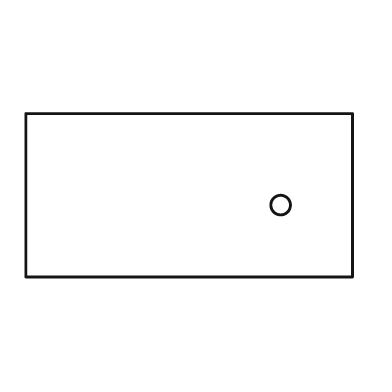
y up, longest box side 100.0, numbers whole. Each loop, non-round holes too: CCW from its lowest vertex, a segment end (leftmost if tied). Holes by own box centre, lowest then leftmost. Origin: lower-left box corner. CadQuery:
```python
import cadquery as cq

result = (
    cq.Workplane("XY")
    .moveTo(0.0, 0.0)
    .lineTo(100.0, 0.0)
    .lineTo(100.0, 50.0)
    .lineTo(0.0, 50.0)
    .close()
    .moveTo(78.0, 22.0)
    .circle(3.0)
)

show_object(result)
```